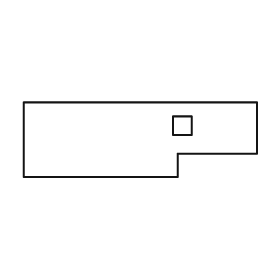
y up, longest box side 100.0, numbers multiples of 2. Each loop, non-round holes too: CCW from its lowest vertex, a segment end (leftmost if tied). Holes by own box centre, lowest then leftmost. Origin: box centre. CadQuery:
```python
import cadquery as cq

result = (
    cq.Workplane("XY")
    .moveTo(-50.0, -16.0)
    .lineTo(16.0, -16.0)
    .lineTo(16.0, -6.0)
    .lineTo(50.0, -6.0)
    .lineTo(50.0, 16.0)
    .lineTo(-50.0, 16.0)
    .close()
    .moveTo(14.0, 2.0)
    .lineTo(22.0, 2.0)
    .lineTo(22.0, 10.0)
    .lineTo(14.0, 10.0)
    .close()
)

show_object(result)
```